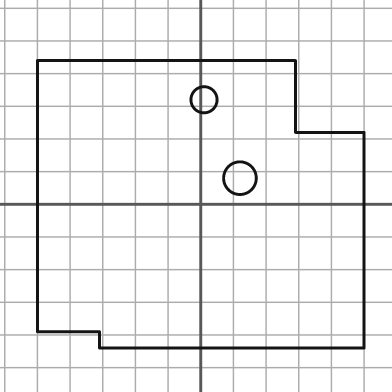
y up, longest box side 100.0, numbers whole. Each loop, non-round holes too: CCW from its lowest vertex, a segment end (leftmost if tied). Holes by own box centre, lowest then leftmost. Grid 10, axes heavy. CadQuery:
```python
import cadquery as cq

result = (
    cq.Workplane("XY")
    .moveTo(-31.0, -44.0)
    .lineTo(50.0, -44.0)
    .lineTo(50.0, 22.0)
    .lineTo(29.0, 22.0)
    .lineTo(29.0, 44.0)
    .lineTo(-50.0, 44.0)
    .lineTo(-50.0, -39.0)
    .lineTo(-31.0, -39.0)
    .close()
    .moveTo(12.0, 8.0)
    .circle(5.0)
    .moveTo(1.0, 32.0)
    .circle(4.0)
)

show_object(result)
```